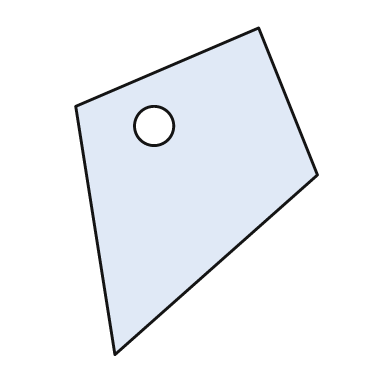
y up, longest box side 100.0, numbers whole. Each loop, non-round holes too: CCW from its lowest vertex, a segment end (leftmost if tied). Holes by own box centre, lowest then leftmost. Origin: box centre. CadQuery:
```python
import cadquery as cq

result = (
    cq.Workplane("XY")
    .moveTo(-25.0, -50.0)
    .lineTo(37.0, 5.0)
    .lineTo(19.0, 50.0)
    .lineTo(-37.0, 26.0)
    .close()
    .moveTo(-13.0, 20.0)
    .circle(6.0)
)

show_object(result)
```